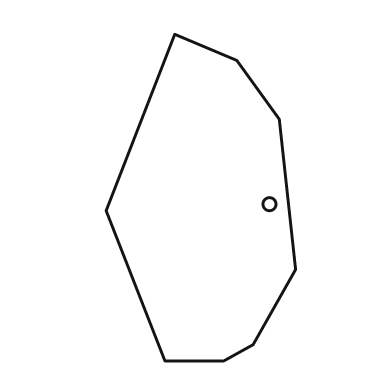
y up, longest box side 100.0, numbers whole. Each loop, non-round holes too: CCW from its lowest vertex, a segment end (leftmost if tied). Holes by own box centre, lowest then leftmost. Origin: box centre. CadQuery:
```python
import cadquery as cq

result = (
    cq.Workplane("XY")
    .moveTo(-11.0, -50.0)
    .lineTo(7.0, -50.0)
    .lineTo(16.0, -45.0)
    .lineTo(29.0, -22.0)
    .lineTo(24.0, 24.0)
    .lineTo(11.0, 42.0)
    .lineTo(-8.0, 50.0)
    .lineTo(-29.0, -4.0)
    .close()
    .moveTo(21.0, -2.0)
    .circle(2.0)
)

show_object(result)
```